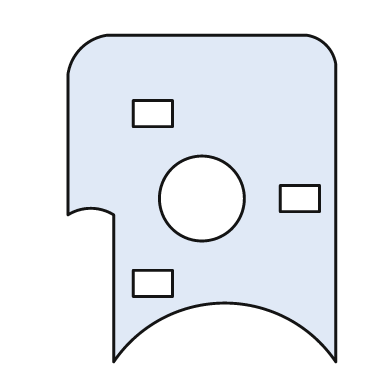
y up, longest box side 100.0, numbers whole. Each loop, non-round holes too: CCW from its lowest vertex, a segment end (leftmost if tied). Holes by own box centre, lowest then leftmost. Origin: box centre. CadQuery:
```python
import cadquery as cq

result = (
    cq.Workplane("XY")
    .moveTo(-27.0, -50.0)
    .threePointArc((7.0, -32.0), (41.0, -50.0))
    .lineTo(41.0, 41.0)
    .threePointArc((38.0, 47.0), (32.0, 50.0))
    .lineTo(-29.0, 50.0)
    .threePointArc((-37.0, 46.0), (-41.0, 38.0))
    .lineTo(-41.0, -5.0)
    .threePointArc((-34.0, -3.0), (-27.0, -5.0))
    .close()
    .moveTo(-21.0, -30.0)
    .lineTo(-9.0, -30.0)
    .lineTo(-9.0, -22.0)
    .lineTo(-21.0, -22.0)
    .close()
    .moveTo(0.0, 0.0)
    .circle(13.0)
    .moveTo(24.0, -4.0)
    .lineTo(36.0, -4.0)
    .lineTo(36.0, 4.0)
    .lineTo(24.0, 4.0)
    .close()
    .moveTo(-21.0, 22.0)
    .lineTo(-9.0, 22.0)
    .lineTo(-9.0, 30.0)
    .lineTo(-21.0, 30.0)
    .close()
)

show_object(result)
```